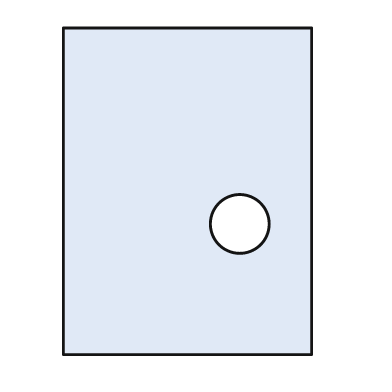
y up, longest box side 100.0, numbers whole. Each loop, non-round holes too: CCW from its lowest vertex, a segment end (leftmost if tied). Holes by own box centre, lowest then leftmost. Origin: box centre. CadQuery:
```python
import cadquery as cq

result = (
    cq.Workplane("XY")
    .moveTo(-38.0, -50.0)
    .lineTo(38.0, -50.0)
    .lineTo(38.0, 50.0)
    .lineTo(-38.0, 50.0)
    .close()
    .moveTo(16.0, -10.0)
    .circle(9.0)
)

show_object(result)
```